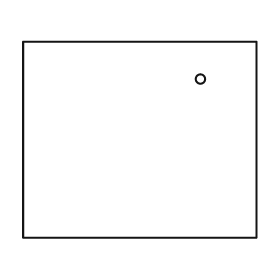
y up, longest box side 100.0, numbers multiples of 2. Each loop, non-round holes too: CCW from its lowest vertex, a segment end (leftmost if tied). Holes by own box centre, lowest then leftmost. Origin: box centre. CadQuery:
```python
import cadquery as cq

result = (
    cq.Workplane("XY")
    .moveTo(-50.0, -42.0)
    .lineTo(50.0, -42.0)
    .lineTo(50.0, 42.0)
    .lineTo(-50.0, 42.0)
    .close()
    .moveTo(26.0, 26.0)
    .circle(2.0)
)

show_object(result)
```